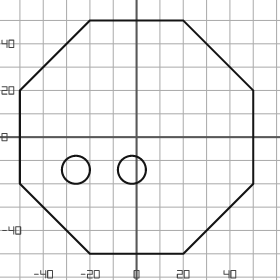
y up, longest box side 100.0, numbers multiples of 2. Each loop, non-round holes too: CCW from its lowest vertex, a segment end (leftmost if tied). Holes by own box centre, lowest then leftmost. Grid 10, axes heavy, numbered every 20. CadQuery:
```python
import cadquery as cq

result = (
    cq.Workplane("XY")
    .moveTo(-20.0, -50.0)
    .lineTo(20.0, -50.0)
    .lineTo(50.0, -20.0)
    .lineTo(50.0, 20.0)
    .lineTo(20.0, 50.0)
    .lineTo(-20.0, 50.0)
    .lineTo(-50.0, 20.0)
    .lineTo(-50.0, -20.0)
    .close()
    .moveTo(-26.0, -14.0)
    .circle(6.0)
    .moveTo(-2.0, -14.0)
    .circle(6.0)
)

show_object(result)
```